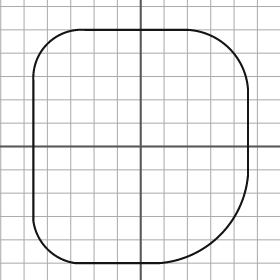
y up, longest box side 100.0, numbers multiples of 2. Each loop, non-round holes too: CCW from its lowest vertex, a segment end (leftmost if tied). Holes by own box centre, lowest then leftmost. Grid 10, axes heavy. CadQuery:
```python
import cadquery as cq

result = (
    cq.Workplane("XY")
    .moveTo(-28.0, -50.0)
    .lineTo(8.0, -50.0)
    .threePointArc((34.0, -38.0), (46.0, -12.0))
    .lineTo(46.0, 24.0)
    .threePointArc((38.0, 42.0), (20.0, 50.0))
    .lineTo(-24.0, 50.0)
    .threePointArc((-40.0, 44.0), (-46.0, 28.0))
    .lineTo(-46.0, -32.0)
    .threePointArc((-40.0, -44.0), (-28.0, -50.0))
    .close()
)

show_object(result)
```